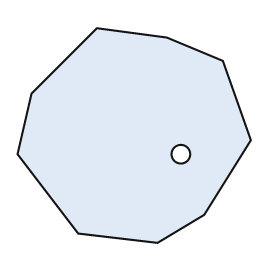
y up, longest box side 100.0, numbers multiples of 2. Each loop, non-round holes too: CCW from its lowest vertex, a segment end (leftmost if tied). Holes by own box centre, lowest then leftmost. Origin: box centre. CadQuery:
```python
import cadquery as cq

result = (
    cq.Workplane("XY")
    .moveTo(10.0, -46.0)
    .lineTo(30.0, -34.0)
    .lineTo(50.0, -2.0)
    .lineTo(38.0, 32.0)
    .lineTo(14.0, 42.0)
    .lineTo(-16.0, 46.0)
    .lineTo(-44.0, 18.0)
    .lineTo(-50.0, -8.0)
    .lineTo(-24.0, -42.0)
    .close()
    .moveTo(20.0, -8.0)
    .circle(4.0)
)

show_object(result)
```